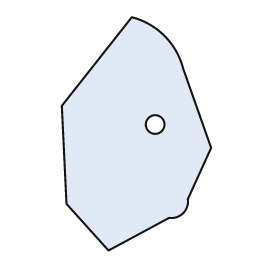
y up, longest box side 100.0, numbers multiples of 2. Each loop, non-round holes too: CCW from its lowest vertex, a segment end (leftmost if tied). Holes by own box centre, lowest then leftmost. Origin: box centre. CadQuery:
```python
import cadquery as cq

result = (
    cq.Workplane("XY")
    .moveTo(-12.0, -50.0)
    .lineTo(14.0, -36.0)
    .threePointArc((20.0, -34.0), (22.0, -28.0))
    .lineTo(32.0, -6.0)
    .lineTo(20.0, 28.0)
    .threePointArc((12.0, 42.0), (-2.0, 50.0))
    .lineTo(-32.0, 12.0)
    .lineTo(-30.0, -30.0)
    .close()
    .moveTo(8.0, 4.0)
    .circle(4.0)
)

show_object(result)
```